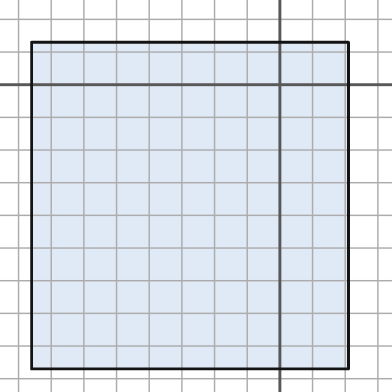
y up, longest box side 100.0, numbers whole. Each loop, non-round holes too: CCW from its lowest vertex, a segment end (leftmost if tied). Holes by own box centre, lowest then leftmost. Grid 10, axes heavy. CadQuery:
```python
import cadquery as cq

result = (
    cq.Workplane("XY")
    .moveTo(-76.0, -87.0)
    .lineTo(21.0, -87.0)
    .lineTo(21.0, 13.0)
    .lineTo(-76.0, 13.0)
    .close()
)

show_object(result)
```